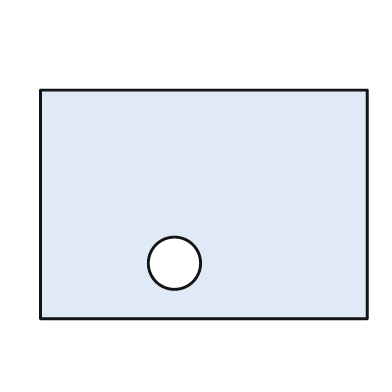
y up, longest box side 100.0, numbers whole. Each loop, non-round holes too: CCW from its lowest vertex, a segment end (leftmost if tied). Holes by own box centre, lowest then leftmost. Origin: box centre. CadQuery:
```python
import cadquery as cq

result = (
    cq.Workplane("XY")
    .moveTo(-50.0, -35.0)
    .lineTo(50.0, -35.0)
    .lineTo(50.0, 35.0)
    .lineTo(-50.0, 35.0)
    .close()
    .moveTo(-9.0, -18.0)
    .circle(8.0)
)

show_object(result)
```